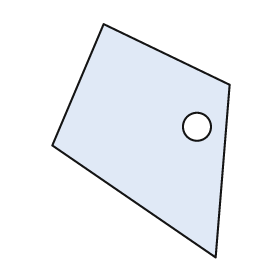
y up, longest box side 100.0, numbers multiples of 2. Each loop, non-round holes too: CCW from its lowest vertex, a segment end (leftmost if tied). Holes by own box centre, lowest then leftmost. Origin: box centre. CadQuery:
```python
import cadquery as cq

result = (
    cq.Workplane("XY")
    .moveTo(32.0, -50.0)
    .lineTo(38.0, 24.0)
    .lineTo(-16.0, 50.0)
    .lineTo(-38.0, -2.0)
    .close()
    .moveTo(24.0, 6.0)
    .circle(6.0)
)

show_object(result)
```